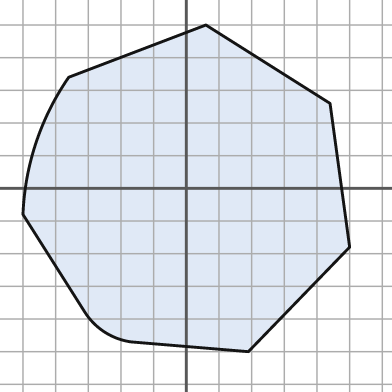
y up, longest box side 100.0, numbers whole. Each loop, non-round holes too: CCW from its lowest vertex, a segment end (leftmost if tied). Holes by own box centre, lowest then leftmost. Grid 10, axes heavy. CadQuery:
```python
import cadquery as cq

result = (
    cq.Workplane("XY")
    .moveTo(19.0, -50.0)
    .lineTo(50.0, -18.0)
    .lineTo(44.0, 26.0)
    .lineTo(6.0, 50.0)
    .lineTo(-36.0, 34.0)
    .threePointArc((-46.0, 14.0), (-50.0, -8.0))
    .lineTo(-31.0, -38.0)
    .threePointArc((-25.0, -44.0), (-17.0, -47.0))
    .close()
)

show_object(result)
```